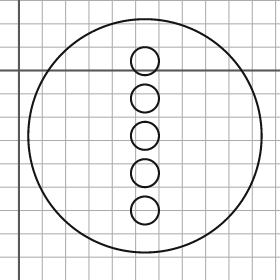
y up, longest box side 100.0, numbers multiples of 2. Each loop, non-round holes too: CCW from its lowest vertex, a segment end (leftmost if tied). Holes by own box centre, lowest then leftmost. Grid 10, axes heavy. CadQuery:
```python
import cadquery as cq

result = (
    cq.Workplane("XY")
    .moveTo(54.0, -28.0)
    .circle(50.0)
    .moveTo(54.0, -60.0)
    .circle(6.0)
    .moveTo(54.0, -44.0)
    .circle(6.0)
    .moveTo(54.0, -28.0)
    .circle(6.0)
    .moveTo(54.0, -12.0)
    .circle(6.0)
    .moveTo(54.0, 4.0)
    .circle(6.0)
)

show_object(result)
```